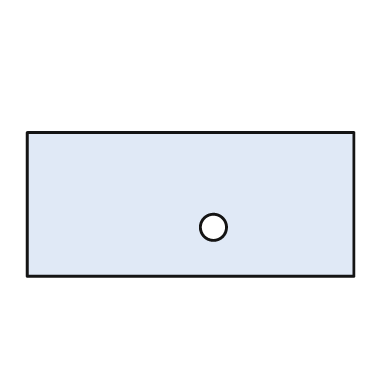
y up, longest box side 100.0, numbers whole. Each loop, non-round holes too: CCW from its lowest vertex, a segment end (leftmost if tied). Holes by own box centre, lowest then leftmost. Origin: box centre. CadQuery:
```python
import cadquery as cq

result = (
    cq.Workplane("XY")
    .moveTo(-50.0, -22.0)
    .lineTo(50.0, -22.0)
    .lineTo(50.0, 22.0)
    .lineTo(-50.0, 22.0)
    .close()
    .moveTo(7.0, -7.0)
    .circle(4.0)
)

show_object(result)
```